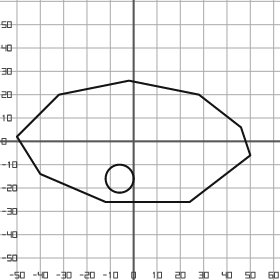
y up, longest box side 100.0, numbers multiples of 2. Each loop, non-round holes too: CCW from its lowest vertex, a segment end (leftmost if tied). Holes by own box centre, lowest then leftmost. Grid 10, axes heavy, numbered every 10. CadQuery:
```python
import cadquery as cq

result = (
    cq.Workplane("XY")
    .moveTo(-12.0, -26.0)
    .lineTo(24.0, -26.0)
    .lineTo(50.0, -6.0)
    .lineTo(46.0, 6.0)
    .lineTo(28.0, 20.0)
    .lineTo(-2.0, 26.0)
    .lineTo(-32.0, 20.0)
    .lineTo(-50.0, 2.0)
    .lineTo(-40.0, -14.0)
    .close()
    .moveTo(-6.0, -16.0)
    .circle(6.0)
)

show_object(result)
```